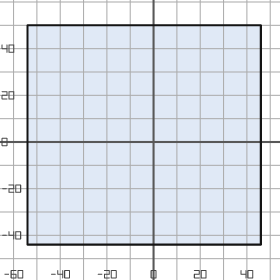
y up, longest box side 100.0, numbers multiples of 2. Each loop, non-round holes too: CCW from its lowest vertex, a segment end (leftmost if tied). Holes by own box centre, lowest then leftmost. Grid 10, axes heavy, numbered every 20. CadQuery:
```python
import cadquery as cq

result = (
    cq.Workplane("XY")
    .moveTo(-54.0, -44.0)
    .lineTo(46.0, -44.0)
    .lineTo(46.0, 50.0)
    .lineTo(-54.0, 50.0)
    .close()
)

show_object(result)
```